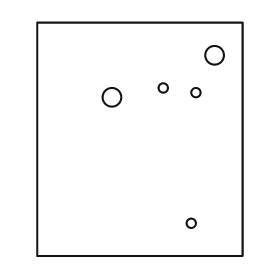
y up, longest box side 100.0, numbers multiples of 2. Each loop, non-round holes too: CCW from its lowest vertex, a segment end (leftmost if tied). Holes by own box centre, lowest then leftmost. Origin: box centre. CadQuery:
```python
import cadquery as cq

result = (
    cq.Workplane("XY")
    .moveTo(-44.0, -50.0)
    .lineTo(44.0, -50.0)
    .lineTo(44.0, 50.0)
    .lineTo(-44.0, 50.0)
    .close()
    .moveTo(22.0, -36.0)
    .circle(2.0)
    .moveTo(-12.0, 18.0)
    .circle(4.0)
    .moveTo(24.0, 20.0)
    .circle(2.0)
    .moveTo(10.0, 22.0)
    .circle(2.0)
    .moveTo(32.0, 36.0)
    .circle(4.0)
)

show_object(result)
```